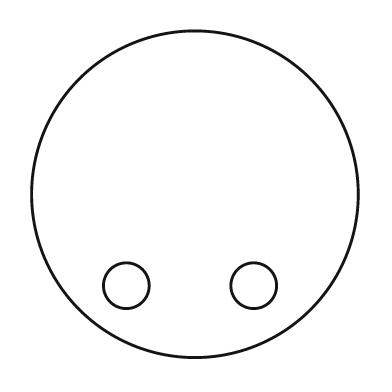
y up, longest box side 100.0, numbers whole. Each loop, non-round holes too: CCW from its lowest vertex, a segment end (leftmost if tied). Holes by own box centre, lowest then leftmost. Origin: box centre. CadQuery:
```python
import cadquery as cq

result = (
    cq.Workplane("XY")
    .moveTo(0.0, 0.0)
    .circle(50.0)
    .moveTo(-21.0, -28.0)
    .circle(7.0)
    .moveTo(18.0, -28.0)
    .circle(7.0)
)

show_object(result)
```